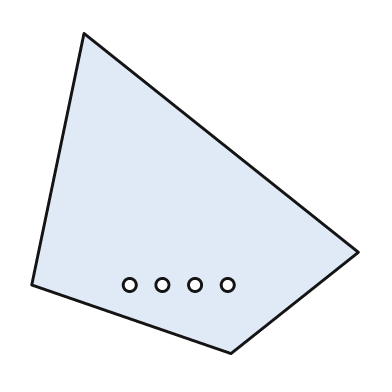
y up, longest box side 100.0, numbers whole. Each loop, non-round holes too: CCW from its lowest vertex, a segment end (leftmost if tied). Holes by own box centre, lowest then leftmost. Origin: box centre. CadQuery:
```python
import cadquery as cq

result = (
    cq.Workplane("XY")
    .moveTo(11.0, -49.0)
    .lineTo(50.0, -18.0)
    .lineTo(-34.0, 49.0)
    .lineTo(-50.0, -28.0)
    .close()
    .moveTo(-20.0, -28.0)
    .circle(2.0)
    .moveTo(-10.0, -28.0)
    .circle(2.0)
    .moveTo(0.0, -28.0)
    .circle(2.0)
    .moveTo(10.0, -28.0)
    .circle(2.0)
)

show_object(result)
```